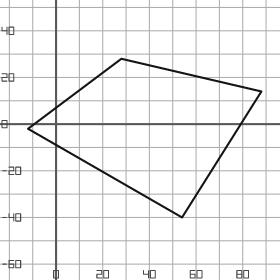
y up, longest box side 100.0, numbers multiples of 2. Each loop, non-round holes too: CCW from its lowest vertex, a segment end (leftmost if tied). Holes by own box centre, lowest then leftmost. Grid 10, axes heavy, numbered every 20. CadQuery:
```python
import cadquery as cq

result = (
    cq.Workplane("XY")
    .moveTo(54.0, -40.0)
    .lineTo(88.0, 14.0)
    .lineTo(28.0, 28.0)
    .lineTo(-12.0, -2.0)
    .close()
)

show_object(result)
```